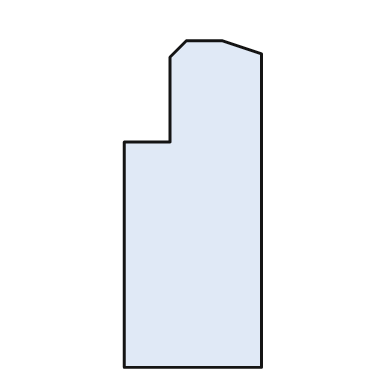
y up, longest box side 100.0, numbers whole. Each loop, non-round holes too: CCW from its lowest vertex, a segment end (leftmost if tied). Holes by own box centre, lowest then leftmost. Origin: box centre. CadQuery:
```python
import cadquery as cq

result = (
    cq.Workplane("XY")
    .moveTo(-21.0, -50.0)
    .lineTo(21.0, -50.0)
    .lineTo(21.0, 46.0)
    .lineTo(9.0, 50.0)
    .lineTo(-2.0, 50.0)
    .lineTo(-7.0, 45.0)
    .lineTo(-7.0, 19.0)
    .lineTo(-21.0, 19.0)
    .close()
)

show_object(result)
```